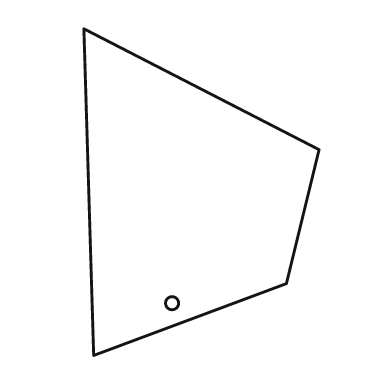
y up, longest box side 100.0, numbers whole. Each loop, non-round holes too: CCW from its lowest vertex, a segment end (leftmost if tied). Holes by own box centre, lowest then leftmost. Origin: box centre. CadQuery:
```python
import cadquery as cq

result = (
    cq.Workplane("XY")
    .moveTo(-33.0, -50.0)
    .lineTo(26.0, -28.0)
    .lineTo(36.0, 13.0)
    .lineTo(-36.0, 50.0)
    .close()
    .moveTo(-9.0, -34.0)
    .circle(2.0)
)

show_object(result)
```